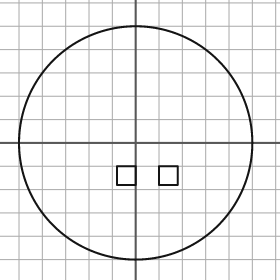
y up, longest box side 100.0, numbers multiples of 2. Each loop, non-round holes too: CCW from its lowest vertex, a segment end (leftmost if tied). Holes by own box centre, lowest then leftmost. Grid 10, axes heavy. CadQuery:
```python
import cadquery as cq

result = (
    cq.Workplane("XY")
    .moveTo(0.0, 0.0)
    .circle(50.0)
    .moveTo(-8.0, -18.0)
    .lineTo(0.0, -18.0)
    .lineTo(0.0, -10.0)
    .lineTo(-8.0, -10.0)
    .close()
    .moveTo(10.0, -18.0)
    .lineTo(18.0, -18.0)
    .lineTo(18.0, -10.0)
    .lineTo(10.0, -10.0)
    .close()
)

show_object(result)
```